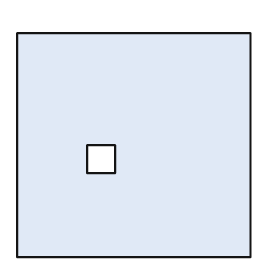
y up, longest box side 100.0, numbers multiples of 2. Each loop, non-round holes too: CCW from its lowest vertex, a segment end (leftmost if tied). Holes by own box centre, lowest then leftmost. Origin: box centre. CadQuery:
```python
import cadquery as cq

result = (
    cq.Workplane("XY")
    .moveTo(-50.0, -48.0)
    .lineTo(50.0, -48.0)
    .lineTo(50.0, 48.0)
    .lineTo(-50.0, 48.0)
    .close()
    .moveTo(-20.0, -12.0)
    .lineTo(-8.0, -12.0)
    .lineTo(-8.0, 0.0)
    .lineTo(-20.0, 0.0)
    .close()
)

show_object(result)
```